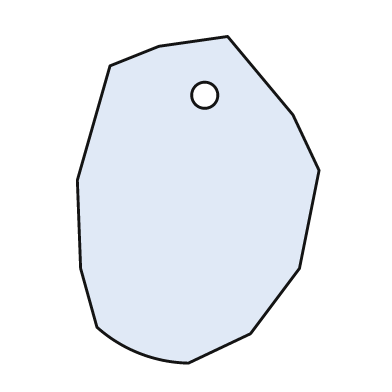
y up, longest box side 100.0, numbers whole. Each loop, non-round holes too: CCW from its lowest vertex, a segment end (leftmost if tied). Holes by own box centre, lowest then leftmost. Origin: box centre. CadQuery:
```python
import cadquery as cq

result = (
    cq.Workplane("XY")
    .moveTo(-3.0, -50.0)
    .lineTo(16.0, -41.0)
    .lineTo(31.0, -21.0)
    .lineTo(37.0, 9.0)
    .lineTo(29.0, 26.0)
    .lineTo(9.0, 50.0)
    .lineTo(-12.0, 47.0)
    .lineTo(-27.0, 41.0)
    .lineTo(-37.0, 6.0)
    .lineTo(-36.0, -21.0)
    .lineTo(-31.0, -39.0)
    .threePointArc((-18.0, -47.0), (-3.0, -50.0))
    .close()
    .moveTo(2.0, 32.0)
    .circle(4.0)
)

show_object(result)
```